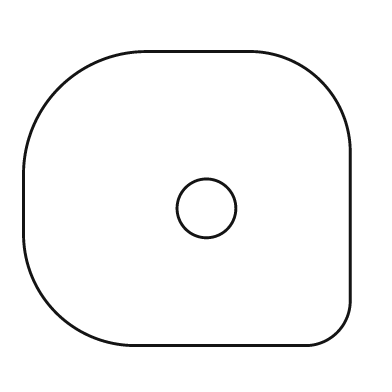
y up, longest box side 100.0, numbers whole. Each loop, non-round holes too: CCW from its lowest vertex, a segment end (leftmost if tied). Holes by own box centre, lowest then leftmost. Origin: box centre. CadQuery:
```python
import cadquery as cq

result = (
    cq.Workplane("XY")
    .moveTo(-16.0, -45.0)
    .lineTo(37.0, -45.0)
    .threePointArc((46.0, -41.0), (50.0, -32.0))
    .lineTo(50.0, 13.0)
    .threePointArc((41.0, 36.0), (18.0, 45.0))
    .lineTo(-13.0, 45.0)
    .threePointArc((-39.0, 34.0), (-50.0, 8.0))
    .lineTo(-50.0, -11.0)
    .threePointArc((-40.0, -35.0), (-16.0, -45.0))
    .close()
    .moveTo(6.0, -3.0)
    .circle(9.0)
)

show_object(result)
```